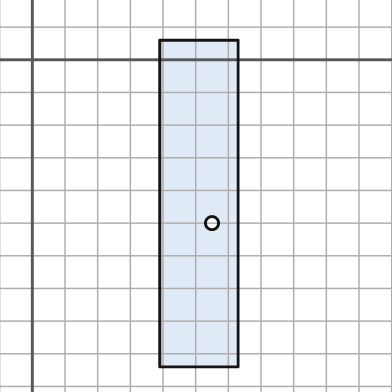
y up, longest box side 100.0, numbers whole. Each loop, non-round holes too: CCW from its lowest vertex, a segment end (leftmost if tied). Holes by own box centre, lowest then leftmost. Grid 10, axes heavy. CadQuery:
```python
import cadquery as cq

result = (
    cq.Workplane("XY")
    .moveTo(39.0, -94.0)
    .lineTo(63.0, -94.0)
    .lineTo(63.0, 6.0)
    .lineTo(39.0, 6.0)
    .close()
    .moveTo(55.0, -50.0)
    .circle(2.0)
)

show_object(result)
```